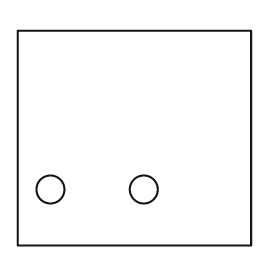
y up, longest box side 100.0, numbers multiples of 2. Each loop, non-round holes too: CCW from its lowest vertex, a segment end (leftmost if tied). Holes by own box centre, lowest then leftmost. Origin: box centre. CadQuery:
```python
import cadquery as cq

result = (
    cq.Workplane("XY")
    .moveTo(-50.0, -46.0)
    .lineTo(50.0, -46.0)
    .lineTo(50.0, 46.0)
    .lineTo(-50.0, 46.0)
    .close()
    .moveTo(-36.0, -22.0)
    .circle(6.0)
    .moveTo(4.0, -22.0)
    .circle(6.0)
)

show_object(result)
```